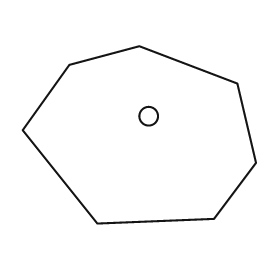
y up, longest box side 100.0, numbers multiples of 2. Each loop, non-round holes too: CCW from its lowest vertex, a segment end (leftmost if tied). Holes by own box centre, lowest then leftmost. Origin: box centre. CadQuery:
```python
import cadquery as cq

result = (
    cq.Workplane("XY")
    .moveTo(-18.0, -38.0)
    .lineTo(32.0, -36.0)
    .lineTo(50.0, -12.0)
    .lineTo(42.0, 22.0)
    .lineTo(0.0, 38.0)
    .lineTo(-30.0, 30.0)
    .lineTo(-50.0, 2.0)
    .close()
    .moveTo(4.0, 8.0)
    .circle(4.0)
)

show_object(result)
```